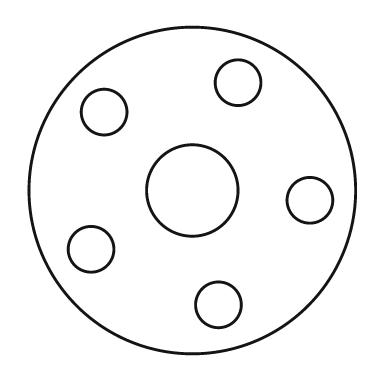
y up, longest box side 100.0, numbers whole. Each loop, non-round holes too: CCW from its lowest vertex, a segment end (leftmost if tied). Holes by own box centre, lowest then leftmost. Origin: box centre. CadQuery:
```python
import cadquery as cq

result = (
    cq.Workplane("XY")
    .moveTo(0.0, 0.0)
    .circle(50.0)
    .moveTo(8.0, -35.0)
    .circle(7.0)
    .moveTo(-31.0, -18.0)
    .circle(7.0)
    .moveTo(36.0, -3.0)
    .circle(7.0)
    .moveTo(0.0, 0.0)
    .circle(14.0)
    .moveTo(-27.0, 24.0)
    .circle(7.0)
    .moveTo(14.0, 33.0)
    .circle(7.0)
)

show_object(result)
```